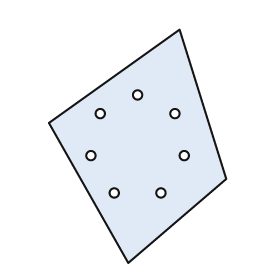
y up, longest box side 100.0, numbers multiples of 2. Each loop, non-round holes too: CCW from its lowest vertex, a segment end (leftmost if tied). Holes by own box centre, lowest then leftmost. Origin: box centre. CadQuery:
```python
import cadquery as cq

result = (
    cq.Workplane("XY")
    .moveTo(-4.0, -50.0)
    .lineTo(38.0, -14.0)
    .lineTo(18.0, 50.0)
    .lineTo(-38.0, 10.0)
    .close()
    .moveTo(-10.0, -20.0)
    .circle(2.0)
    .moveTo(10.0, -20.0)
    .circle(2.0)
    .moveTo(-20.0, -4.0)
    .circle(2.0)
    .moveTo(20.0, -4.0)
    .circle(2.0)
    .moveTo(-16.0, 14.0)
    .circle(2.0)
    .moveTo(16.0, 14.0)
    .circle(2.0)
    .moveTo(0.0, 22.0)
    .circle(2.0)
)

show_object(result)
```